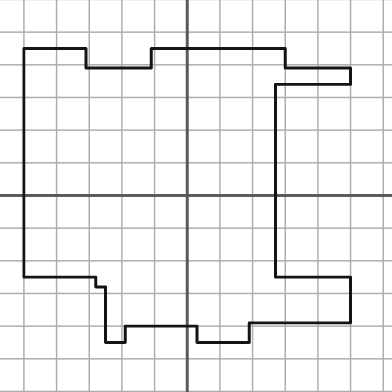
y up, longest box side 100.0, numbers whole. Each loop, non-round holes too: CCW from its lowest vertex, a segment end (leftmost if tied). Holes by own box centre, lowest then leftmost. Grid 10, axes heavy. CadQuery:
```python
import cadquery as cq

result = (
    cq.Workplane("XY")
    .moveTo(-25.0, -45.0)
    .lineTo(-19.0, -45.0)
    .lineTo(-19.0, -40.0)
    .lineTo(3.0, -40.0)
    .lineTo(3.0, -45.0)
    .lineTo(19.0, -45.0)
    .lineTo(19.0, -39.0)
    .lineTo(50.0, -39.0)
    .lineTo(50.0, -25.0)
    .lineTo(27.0, -25.0)
    .lineTo(27.0, 34.0)
    .lineTo(50.0, 34.0)
    .lineTo(50.0, 39.0)
    .lineTo(30.0, 39.0)
    .lineTo(30.0, 45.0)
    .lineTo(-11.0, 45.0)
    .lineTo(-11.0, 39.0)
    .lineTo(-31.0, 39.0)
    .lineTo(-31.0, 45.0)
    .lineTo(-50.0, 45.0)
    .lineTo(-50.0, -25.0)
    .lineTo(-28.0, -25.0)
    .lineTo(-28.0, -28.0)
    .lineTo(-25.0, -28.0)
    .close()
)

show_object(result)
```